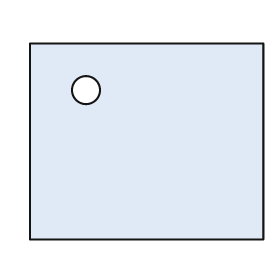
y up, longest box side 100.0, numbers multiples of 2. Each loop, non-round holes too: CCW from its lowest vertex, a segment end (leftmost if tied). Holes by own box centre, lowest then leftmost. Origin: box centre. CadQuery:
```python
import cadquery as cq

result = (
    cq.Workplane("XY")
    .moveTo(-50.0, -42.0)
    .lineTo(50.0, -42.0)
    .lineTo(50.0, 42.0)
    .lineTo(-50.0, 42.0)
    .close()
    .moveTo(-26.0, 22.0)
    .circle(6.0)
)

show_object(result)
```